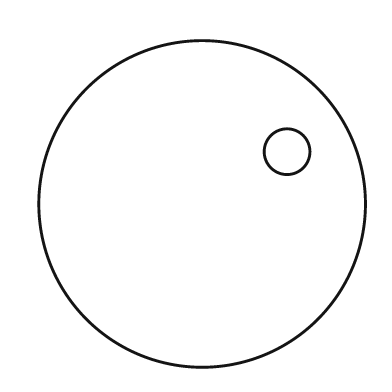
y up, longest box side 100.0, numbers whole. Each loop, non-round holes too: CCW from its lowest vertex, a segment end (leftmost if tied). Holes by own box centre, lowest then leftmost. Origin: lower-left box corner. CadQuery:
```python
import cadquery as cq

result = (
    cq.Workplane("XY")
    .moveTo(50.0, 50.0)
    .circle(50.0)
    .moveTo(76.0, 66.0)
    .circle(7.0)
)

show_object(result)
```